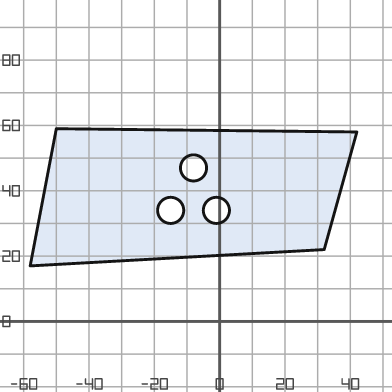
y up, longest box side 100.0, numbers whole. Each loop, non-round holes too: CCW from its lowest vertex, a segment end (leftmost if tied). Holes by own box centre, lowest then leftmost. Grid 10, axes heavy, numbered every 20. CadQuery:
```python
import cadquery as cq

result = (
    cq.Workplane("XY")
    .moveTo(-58.0, 17.0)
    .lineTo(32.0, 22.0)
    .lineTo(42.0, 58.0)
    .lineTo(-50.0, 59.0)
    .close()
    .moveTo(-15.0, 34.0)
    .circle(4.0)
    .moveTo(-1.0, 34.0)
    .circle(4.0)
    .moveTo(-8.0, 47.0)
    .circle(4.0)
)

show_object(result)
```